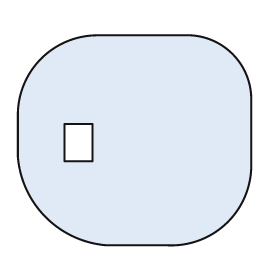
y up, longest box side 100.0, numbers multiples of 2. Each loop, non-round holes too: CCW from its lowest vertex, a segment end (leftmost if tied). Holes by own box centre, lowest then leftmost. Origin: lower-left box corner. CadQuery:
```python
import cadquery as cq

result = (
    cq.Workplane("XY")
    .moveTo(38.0, 0.0)
    .lineTo(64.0, 0.0)
    .threePointArc((90.0, 10.0), (100.0, 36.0))
    .lineTo(100.0, 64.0)
    .threePointArc((92.0, 82.0), (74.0, 90.0))
    .lineTo(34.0, 90.0)
    .threePointArc((10.0, 80.0), (0.0, 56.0))
    .lineTo(0.0, 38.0)
    .threePointArc((12.0, 12.0), (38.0, 0.0))
    .close()
    .moveTo(20.0, 36.0)
    .lineTo(32.0, 36.0)
    .lineTo(32.0, 52.0)
    .lineTo(20.0, 52.0)
    .close()
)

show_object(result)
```